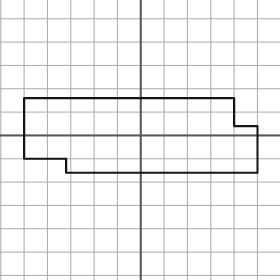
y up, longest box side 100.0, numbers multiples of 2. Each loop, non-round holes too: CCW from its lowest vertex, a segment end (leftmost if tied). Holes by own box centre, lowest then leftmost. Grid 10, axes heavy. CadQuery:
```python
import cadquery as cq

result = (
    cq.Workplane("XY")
    .moveTo(-32.0, -16.0)
    .lineTo(50.0, -16.0)
    .lineTo(50.0, 4.0)
    .lineTo(40.0, 4.0)
    .lineTo(40.0, 16.0)
    .lineTo(-50.0, 16.0)
    .lineTo(-50.0, -10.0)
    .lineTo(-32.0, -10.0)
    .close()
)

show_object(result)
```